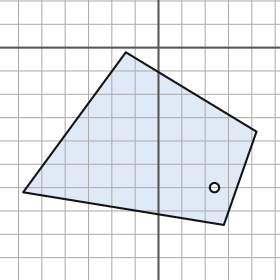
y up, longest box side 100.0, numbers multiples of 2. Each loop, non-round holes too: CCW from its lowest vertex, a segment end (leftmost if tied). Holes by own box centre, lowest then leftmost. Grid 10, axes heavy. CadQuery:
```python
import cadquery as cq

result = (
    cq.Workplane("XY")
    .moveTo(28.0, -76.0)
    .lineTo(42.0, -36.0)
    .lineTo(-14.0, -2.0)
    .lineTo(-58.0, -62.0)
    .close()
    .moveTo(24.0, -60.0)
    .circle(2.0)
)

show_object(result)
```